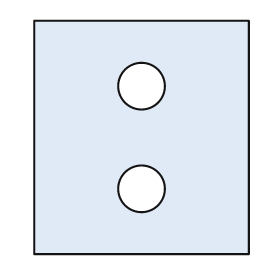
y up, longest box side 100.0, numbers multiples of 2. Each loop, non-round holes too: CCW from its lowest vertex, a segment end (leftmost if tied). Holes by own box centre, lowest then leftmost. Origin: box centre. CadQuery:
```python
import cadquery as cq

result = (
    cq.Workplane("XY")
    .moveTo(-46.0, -50.0)
    .lineTo(46.0, -50.0)
    .lineTo(46.0, 50.0)
    .lineTo(-46.0, 50.0)
    .close()
    .moveTo(0.0, -22.0)
    .circle(10.0)
    .moveTo(0.0, 22.0)
    .circle(10.0)
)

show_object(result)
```